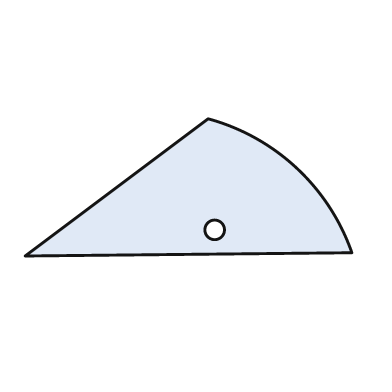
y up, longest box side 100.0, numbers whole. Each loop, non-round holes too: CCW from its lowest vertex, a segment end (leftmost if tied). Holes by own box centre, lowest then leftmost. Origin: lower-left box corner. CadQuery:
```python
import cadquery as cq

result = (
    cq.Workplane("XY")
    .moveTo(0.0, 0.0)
    .lineTo(100.0, 1.0)
    .threePointArc((83.0, 27.0), (56.0, 42.0))
    .close()
    .moveTo(58.0, 8.0)
    .circle(3.0)
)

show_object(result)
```